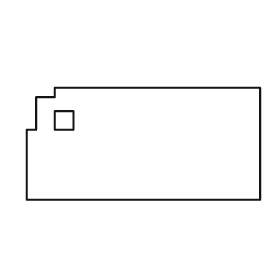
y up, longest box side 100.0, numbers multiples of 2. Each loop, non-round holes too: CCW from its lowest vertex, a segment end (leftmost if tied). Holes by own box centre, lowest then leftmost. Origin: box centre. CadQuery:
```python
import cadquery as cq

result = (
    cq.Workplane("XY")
    .moveTo(-50.0, -24.0)
    .lineTo(50.0, -24.0)
    .lineTo(50.0, 24.0)
    .lineTo(-38.0, 24.0)
    .lineTo(-38.0, 20.0)
    .lineTo(-46.0, 20.0)
    .lineTo(-46.0, 6.0)
    .lineTo(-50.0, 6.0)
    .close()
    .moveTo(-38.0, 6.0)
    .lineTo(-30.0, 6.0)
    .lineTo(-30.0, 14.0)
    .lineTo(-38.0, 14.0)
    .close()
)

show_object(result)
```